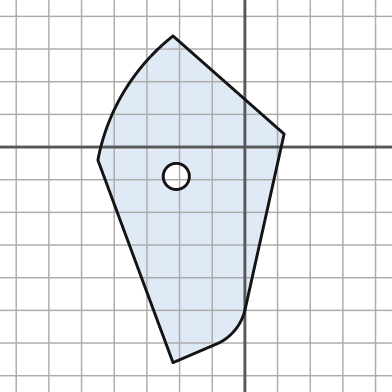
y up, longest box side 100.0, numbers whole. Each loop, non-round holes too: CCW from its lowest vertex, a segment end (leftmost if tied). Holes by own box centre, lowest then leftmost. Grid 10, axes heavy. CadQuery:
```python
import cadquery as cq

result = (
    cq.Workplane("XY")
    .moveTo(-22.0, -66.0)
    .lineTo(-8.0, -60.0)
    .threePointArc((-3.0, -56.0), (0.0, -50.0))
    .lineTo(12.0, 4.0)
    .lineTo(-22.0, 34.0)
    .threePointArc((-37.0, 17.0), (-45.0, -4.0))
    .close()
    .moveTo(-21.0, -9.0)
    .circle(4.0)
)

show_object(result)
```